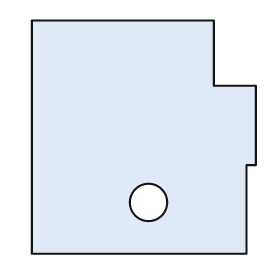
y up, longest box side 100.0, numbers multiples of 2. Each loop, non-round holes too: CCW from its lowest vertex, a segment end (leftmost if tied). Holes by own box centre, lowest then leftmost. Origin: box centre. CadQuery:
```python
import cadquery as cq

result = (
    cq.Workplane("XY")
    .moveTo(-48.0, -50.0)
    .lineTo(44.0, -50.0)
    .lineTo(44.0, -12.0)
    .lineTo(48.0, -12.0)
    .lineTo(48.0, 22.0)
    .lineTo(30.0, 22.0)
    .lineTo(30.0, 50.0)
    .lineTo(-48.0, 50.0)
    .close()
    .moveTo(2.0, -28.0)
    .circle(8.0)
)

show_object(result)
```